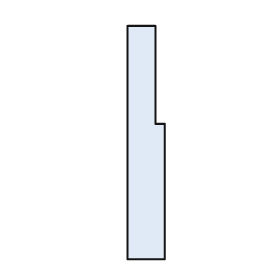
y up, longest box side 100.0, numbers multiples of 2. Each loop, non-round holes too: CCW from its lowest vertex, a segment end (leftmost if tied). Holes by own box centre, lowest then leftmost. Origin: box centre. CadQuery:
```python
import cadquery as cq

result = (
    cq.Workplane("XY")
    .moveTo(-8.0, -50.0)
    .lineTo(8.0, -50.0)
    .lineTo(8.0, 8.0)
    .lineTo(4.0, 8.0)
    .lineTo(4.0, 50.0)
    .lineTo(-8.0, 50.0)
    .close()
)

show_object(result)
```